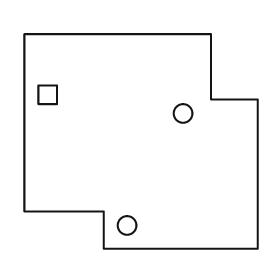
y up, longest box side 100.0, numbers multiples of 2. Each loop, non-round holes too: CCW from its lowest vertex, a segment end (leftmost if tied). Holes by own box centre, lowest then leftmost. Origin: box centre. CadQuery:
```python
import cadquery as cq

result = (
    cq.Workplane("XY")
    .moveTo(-16.0, -46.0)
    .lineTo(50.0, -46.0)
    .lineTo(50.0, 18.0)
    .lineTo(30.0, 18.0)
    .lineTo(30.0, 46.0)
    .lineTo(-50.0, 46.0)
    .lineTo(-50.0, -30.0)
    .lineTo(-16.0, -30.0)
    .close()
    .moveTo(-6.0, -36.0)
    .circle(4.0)
    .moveTo(18.0, 12.0)
    .circle(4.0)
    .moveTo(-44.0, 16.0)
    .lineTo(-36.0, 16.0)
    .lineTo(-36.0, 24.0)
    .lineTo(-44.0, 24.0)
    .close()
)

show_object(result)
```